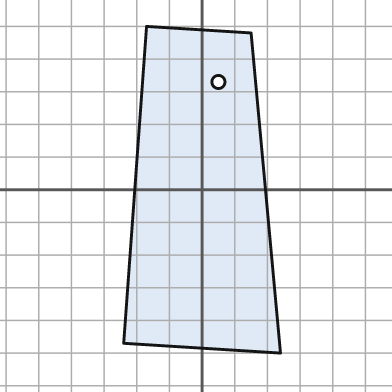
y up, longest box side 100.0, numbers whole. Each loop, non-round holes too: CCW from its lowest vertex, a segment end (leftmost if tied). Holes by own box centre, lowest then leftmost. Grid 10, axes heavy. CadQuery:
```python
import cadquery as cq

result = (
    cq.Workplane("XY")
    .moveTo(24.0, -50.0)
    .lineTo(15.0, 48.0)
    .lineTo(-17.0, 50.0)
    .lineTo(-24.0, -47.0)
    .close()
    .moveTo(5.0, 33.0)
    .circle(2.0)
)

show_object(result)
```